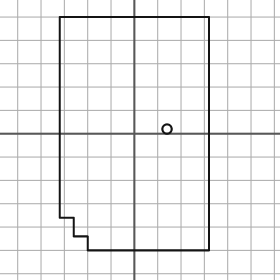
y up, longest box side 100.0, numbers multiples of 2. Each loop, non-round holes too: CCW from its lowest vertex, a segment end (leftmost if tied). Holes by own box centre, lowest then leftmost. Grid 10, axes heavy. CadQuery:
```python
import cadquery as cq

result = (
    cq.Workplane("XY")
    .moveTo(-20.0, -50.0)
    .lineTo(32.0, -50.0)
    .lineTo(32.0, 50.0)
    .lineTo(-32.0, 50.0)
    .lineTo(-32.0, -36.0)
    .lineTo(-26.0, -36.0)
    .lineTo(-26.0, -44.0)
    .lineTo(-20.0, -44.0)
    .close()
    .moveTo(14.0, 2.0)
    .circle(2.0)
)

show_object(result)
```